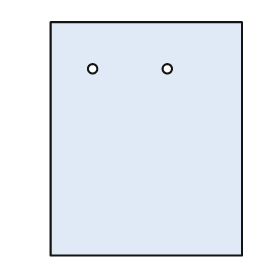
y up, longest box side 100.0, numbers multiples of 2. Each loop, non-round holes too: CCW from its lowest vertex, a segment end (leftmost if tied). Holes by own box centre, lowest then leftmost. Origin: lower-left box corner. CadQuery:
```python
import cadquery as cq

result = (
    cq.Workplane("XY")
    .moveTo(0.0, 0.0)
    .lineTo(82.0, 0.0)
    .lineTo(82.0, 100.0)
    .lineTo(0.0, 100.0)
    .close()
    .moveTo(18.0, 80.0)
    .circle(2.0)
    .moveTo(50.0, 80.0)
    .circle(2.0)
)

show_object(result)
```